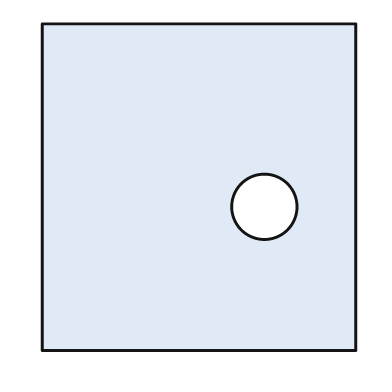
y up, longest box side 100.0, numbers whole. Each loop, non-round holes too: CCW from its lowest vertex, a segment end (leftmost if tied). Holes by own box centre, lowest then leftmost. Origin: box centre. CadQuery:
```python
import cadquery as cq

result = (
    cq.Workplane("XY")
    .moveTo(-48.0, -50.0)
    .lineTo(48.0, -50.0)
    .lineTo(48.0, 50.0)
    .lineTo(-48.0, 50.0)
    .close()
    .moveTo(20.0, -6.0)
    .circle(10.0)
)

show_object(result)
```